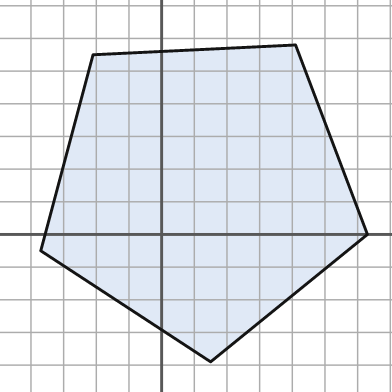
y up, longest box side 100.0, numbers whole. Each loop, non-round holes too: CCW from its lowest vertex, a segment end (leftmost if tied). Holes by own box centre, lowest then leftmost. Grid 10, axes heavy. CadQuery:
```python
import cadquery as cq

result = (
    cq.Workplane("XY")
    .moveTo(15.0, -39.0)
    .lineTo(63.0, 0.0)
    .lineTo(41.0, 58.0)
    .lineTo(-21.0, 55.0)
    .lineTo(-37.0, -5.0)
    .close()
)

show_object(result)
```